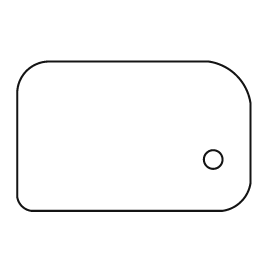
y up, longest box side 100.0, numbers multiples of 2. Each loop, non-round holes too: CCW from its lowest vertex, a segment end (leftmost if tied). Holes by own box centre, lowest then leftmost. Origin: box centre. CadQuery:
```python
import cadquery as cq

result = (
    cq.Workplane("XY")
    .moveTo(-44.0, -32.0)
    .lineTo(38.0, -32.0)
    .threePointArc((46.0, -28.0), (50.0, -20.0))
    .lineTo(50.0, 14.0)
    .threePointArc((44.0, 26.0), (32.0, 32.0))
    .lineTo(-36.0, 32.0)
    .threePointArc((-46.0, 28.0), (-50.0, 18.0))
    .lineTo(-50.0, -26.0)
    .threePointArc((-48.0, -30.0), (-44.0, -32.0))
    .close()
    .moveTo(34.0, -10.0)
    .circle(4.0)
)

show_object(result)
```